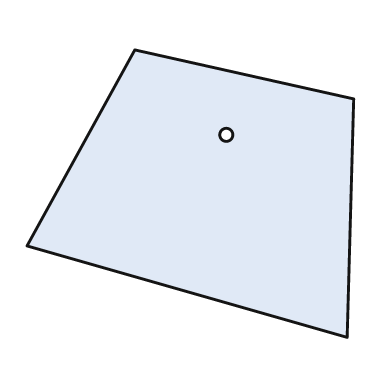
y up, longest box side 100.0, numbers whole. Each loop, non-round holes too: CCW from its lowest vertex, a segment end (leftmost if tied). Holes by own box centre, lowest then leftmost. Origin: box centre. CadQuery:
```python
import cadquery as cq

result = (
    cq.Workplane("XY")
    .moveTo(48.0, -44.0)
    .lineTo(50.0, 29.0)
    .lineTo(-17.0, 44.0)
    .lineTo(-50.0, -16.0)
    .close()
    .moveTo(11.0, 18.0)
    .circle(2.0)
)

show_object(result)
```